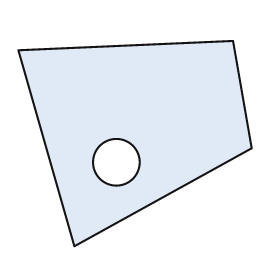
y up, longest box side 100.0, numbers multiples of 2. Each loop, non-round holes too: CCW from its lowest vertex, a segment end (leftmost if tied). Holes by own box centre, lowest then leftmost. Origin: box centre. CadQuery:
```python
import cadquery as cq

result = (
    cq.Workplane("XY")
    .moveTo(-26.0, -44.0)
    .lineTo(50.0, -2.0)
    .lineTo(42.0, 44.0)
    .lineTo(-50.0, 40.0)
    .close()
    .moveTo(-8.0, -8.0)
    .circle(10.0)
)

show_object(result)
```